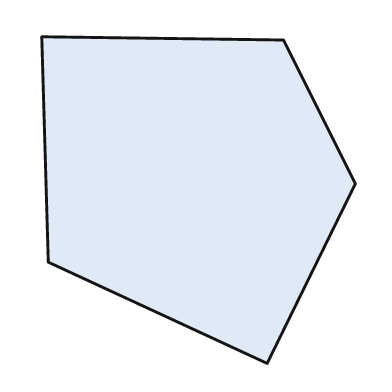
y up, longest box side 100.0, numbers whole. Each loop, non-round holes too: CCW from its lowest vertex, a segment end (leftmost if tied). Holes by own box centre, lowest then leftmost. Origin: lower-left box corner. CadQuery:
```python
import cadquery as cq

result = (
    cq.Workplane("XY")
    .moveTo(69.0, 0.0)
    .lineTo(96.0, 55.0)
    .lineTo(74.0, 99.0)
    .lineTo(0.0, 100.0)
    .lineTo(2.0, 31.0)
    .close()
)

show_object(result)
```